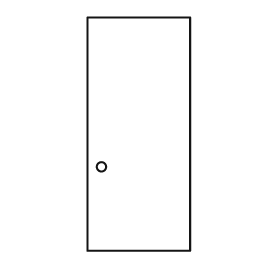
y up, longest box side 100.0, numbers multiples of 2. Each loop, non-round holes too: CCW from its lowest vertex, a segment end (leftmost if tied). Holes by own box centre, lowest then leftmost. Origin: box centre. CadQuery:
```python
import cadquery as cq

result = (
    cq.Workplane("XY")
    .moveTo(-22.0, -50.0)
    .lineTo(22.0, -50.0)
    .lineTo(22.0, 50.0)
    .lineTo(-22.0, 50.0)
    .close()
    .moveTo(-16.0, -14.0)
    .circle(2.0)
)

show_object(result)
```